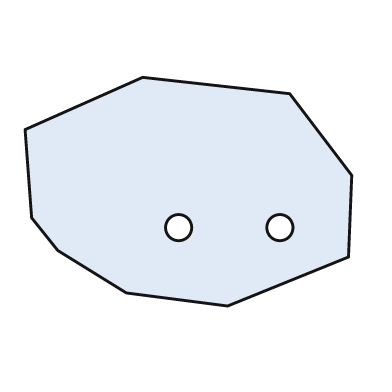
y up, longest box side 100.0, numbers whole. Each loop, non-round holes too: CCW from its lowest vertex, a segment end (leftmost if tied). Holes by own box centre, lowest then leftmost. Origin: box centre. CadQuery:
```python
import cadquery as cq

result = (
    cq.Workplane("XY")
    .moveTo(12.0, -35.0)
    .lineTo(49.0, -20.0)
    .lineTo(50.0, 5.0)
    .lineTo(31.0, 30.0)
    .lineTo(-14.0, 35.0)
    .lineTo(-50.0, 19.0)
    .lineTo(-48.0, -8.0)
    .lineTo(-40.0, -18.0)
    .lineTo(-19.0, -31.0)
    .close()
    .moveTo(-3.0, -11.0)
    .circle(4.0)
    .moveTo(28.0, -11.0)
    .circle(4.0)
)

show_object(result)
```